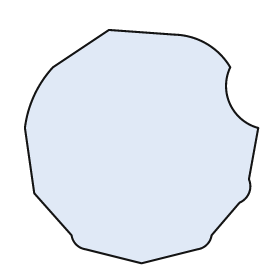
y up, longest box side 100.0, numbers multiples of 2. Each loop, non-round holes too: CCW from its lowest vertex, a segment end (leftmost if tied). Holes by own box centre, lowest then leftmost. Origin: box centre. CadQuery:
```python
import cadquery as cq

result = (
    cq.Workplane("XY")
    .moveTo(0.0, -50.0)
    .lineTo(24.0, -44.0)
    .threePointArc((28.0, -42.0), (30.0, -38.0))
    .lineTo(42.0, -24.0)
    .threePointArc((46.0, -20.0), (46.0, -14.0))
    .lineTo(50.0, 8.0)
    .threePointArc((38.0, 18.0), (38.0, 34.0))
    .threePointArc((28.0, 44.0), (14.0, 48.0))
    .lineTo(-14.0, 50.0)
    .lineTo(-38.0, 34.0)
    .threePointArc((-46.0, 22.0), (-50.0, 8.0))
    .lineTo(-46.0, -20.0)
    .lineTo(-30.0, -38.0)
    .threePointArc((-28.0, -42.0), (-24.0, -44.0))
    .close()
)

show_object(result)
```